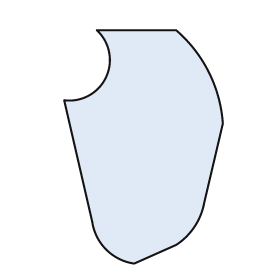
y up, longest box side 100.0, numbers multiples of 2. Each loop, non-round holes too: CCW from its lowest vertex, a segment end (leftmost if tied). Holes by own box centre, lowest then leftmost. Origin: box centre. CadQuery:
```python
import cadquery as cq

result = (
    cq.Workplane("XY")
    .moveTo(-4.0, -50.0)
    .lineTo(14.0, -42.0)
    .threePointArc((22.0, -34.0), (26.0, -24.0))
    .lineTo(34.0, 10.0)
    .threePointArc((28.0, 32.0), (14.0, 50.0))
    .lineTo(-20.0, 50.0)
    .threePointArc((-16.0, 30.0), (-34.0, 20.0))
    .lineTo(-22.0, -32.0)
    .threePointArc((-16.0, -44.0), (-4.0, -50.0))
    .close()
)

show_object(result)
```